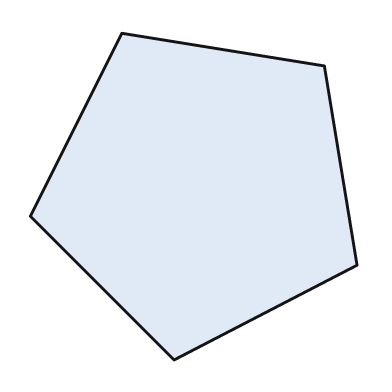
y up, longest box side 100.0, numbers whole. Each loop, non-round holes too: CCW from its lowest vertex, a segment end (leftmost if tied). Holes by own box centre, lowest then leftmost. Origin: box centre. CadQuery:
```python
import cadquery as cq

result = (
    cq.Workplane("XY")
    .moveTo(-6.0, -50.0)
    .lineTo(50.0, -21.0)
    .lineTo(40.0, 40.0)
    .lineTo(-22.0, 50.0)
    .lineTo(-50.0, -6.0)
    .close()
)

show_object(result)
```